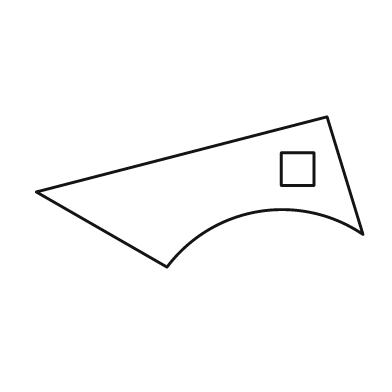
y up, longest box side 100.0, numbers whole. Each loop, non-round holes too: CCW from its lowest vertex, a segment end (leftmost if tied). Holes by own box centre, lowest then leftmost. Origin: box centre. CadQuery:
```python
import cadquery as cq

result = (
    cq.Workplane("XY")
    .moveTo(-10.0, -23.0)
    .threePointArc((18.0, -6.0), (50.0, -13.0))
    .lineTo(39.0, 23.0)
    .lineTo(-50.0, 0.0)
    .close()
    .moveTo(25.0, 2.0)
    .lineTo(35.0, 2.0)
    .lineTo(35.0, 12.0)
    .lineTo(25.0, 12.0)
    .close()
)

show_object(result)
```